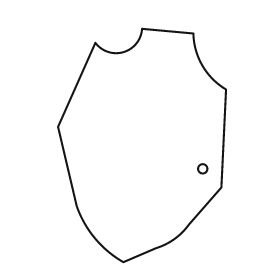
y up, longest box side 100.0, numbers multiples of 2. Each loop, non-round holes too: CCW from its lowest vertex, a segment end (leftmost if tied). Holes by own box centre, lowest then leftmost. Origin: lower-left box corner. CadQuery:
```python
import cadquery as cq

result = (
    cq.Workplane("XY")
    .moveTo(28.0, 0.0)
    .lineTo(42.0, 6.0)
    .threePointArc((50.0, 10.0), (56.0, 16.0))
    .lineTo(70.0, 32.0)
    .lineTo(72.0, 74.0)
    .threePointArc((62.0, 84.0), (58.0, 98.0))
    .lineTo(36.0, 100.0)
    .threePointArc((28.0, 90.0), (16.0, 94.0))
    .lineTo(0.0, 58.0)
    .lineTo(8.0, 24.0)
    .threePointArc((16.0, 10.0), (28.0, 0.0))
    .close()
    .moveTo(62.0, 40.0)
    .circle(2.0)
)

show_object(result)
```